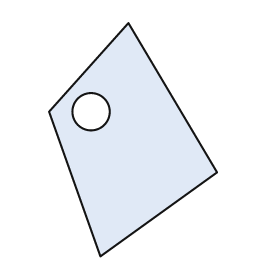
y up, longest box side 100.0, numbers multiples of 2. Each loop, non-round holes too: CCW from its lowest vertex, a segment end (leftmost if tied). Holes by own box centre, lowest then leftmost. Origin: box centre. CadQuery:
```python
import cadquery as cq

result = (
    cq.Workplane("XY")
    .moveTo(-14.0, -50.0)
    .lineTo(36.0, -14.0)
    .lineTo(-2.0, 50.0)
    .lineTo(-36.0, 12.0)
    .close()
    .moveTo(-18.0, 12.0)
    .circle(8.0)
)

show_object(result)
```